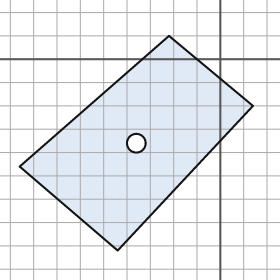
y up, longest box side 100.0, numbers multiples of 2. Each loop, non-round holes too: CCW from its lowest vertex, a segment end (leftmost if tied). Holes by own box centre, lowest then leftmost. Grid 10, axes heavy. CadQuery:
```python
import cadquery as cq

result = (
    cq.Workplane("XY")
    .moveTo(-44.0, -82.0)
    .lineTo(14.0, -20.0)
    .lineTo(-22.0, 10.0)
    .lineTo(-86.0, -46.0)
    .close()
    .moveTo(-36.0, -36.0)
    .circle(4.0)
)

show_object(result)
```